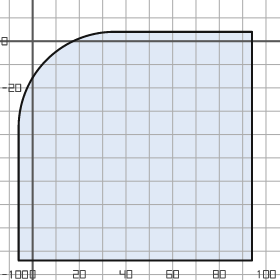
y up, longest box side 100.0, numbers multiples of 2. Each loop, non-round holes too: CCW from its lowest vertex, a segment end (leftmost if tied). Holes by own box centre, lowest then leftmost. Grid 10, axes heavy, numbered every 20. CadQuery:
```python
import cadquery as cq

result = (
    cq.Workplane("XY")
    .moveTo(-6.0, -94.0)
    .lineTo(94.0, -94.0)
    .lineTo(94.0, 4.0)
    .lineTo(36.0, 4.0)
    .threePointArc((6.0, -8.0), (-6.0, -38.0))
    .close()
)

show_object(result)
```